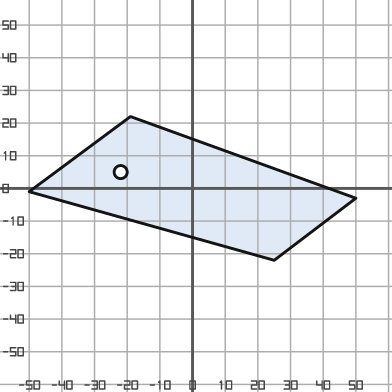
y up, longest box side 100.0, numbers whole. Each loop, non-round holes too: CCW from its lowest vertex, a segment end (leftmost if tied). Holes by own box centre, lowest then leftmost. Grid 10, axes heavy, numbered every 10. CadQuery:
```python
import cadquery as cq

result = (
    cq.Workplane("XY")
    .moveTo(25.0, -22.0)
    .lineTo(50.0, -3.0)
    .lineTo(-19.0, 22.0)
    .lineTo(-50.0, -1.0)
    .close()
    .moveTo(-22.0, 5.0)
    .circle(2.0)
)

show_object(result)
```